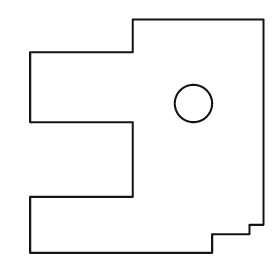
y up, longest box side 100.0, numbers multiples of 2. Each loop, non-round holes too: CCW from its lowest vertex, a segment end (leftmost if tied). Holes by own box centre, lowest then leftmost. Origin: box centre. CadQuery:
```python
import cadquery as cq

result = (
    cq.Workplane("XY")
    .moveTo(-50.0, -50.0)
    .lineTo(28.0, -50.0)
    .lineTo(28.0, -42.0)
    .lineTo(44.0, -42.0)
    .lineTo(44.0, -38.0)
    .lineTo(50.0, -38.0)
    .lineTo(50.0, 50.0)
    .lineTo(-6.0, 50.0)
    .lineTo(-6.0, 36.0)
    .lineTo(-50.0, 36.0)
    .lineTo(-50.0, 6.0)
    .lineTo(-6.0, 6.0)
    .lineTo(-6.0, -26.0)
    .lineTo(-50.0, -26.0)
    .close()
    .moveTo(20.0, 14.0)
    .circle(8.0)
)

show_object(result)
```